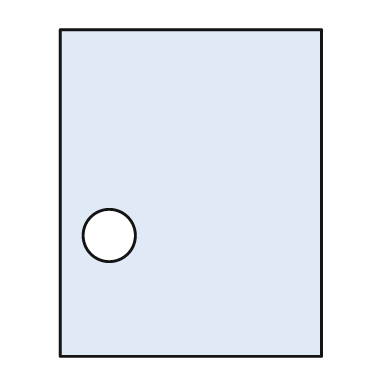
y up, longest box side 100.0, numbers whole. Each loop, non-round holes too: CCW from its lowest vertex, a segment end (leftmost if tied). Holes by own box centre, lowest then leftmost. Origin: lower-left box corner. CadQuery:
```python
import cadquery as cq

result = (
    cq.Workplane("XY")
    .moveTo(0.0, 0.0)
    .lineTo(80.0, 0.0)
    .lineTo(80.0, 100.0)
    .lineTo(0.0, 100.0)
    .close()
    .moveTo(15.0, 37.0)
    .circle(8.0)
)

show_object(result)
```